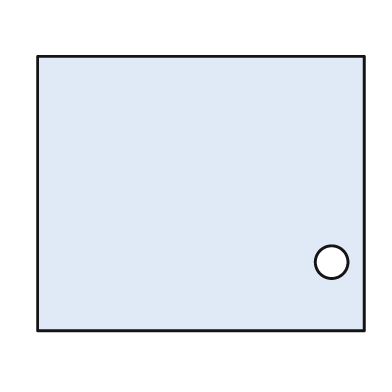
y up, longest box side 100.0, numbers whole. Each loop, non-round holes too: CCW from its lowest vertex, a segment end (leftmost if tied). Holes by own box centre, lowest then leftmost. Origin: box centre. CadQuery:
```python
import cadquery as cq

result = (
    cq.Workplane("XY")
    .moveTo(-50.0, -42.0)
    .lineTo(50.0, -42.0)
    .lineTo(50.0, 42.0)
    .lineTo(-50.0, 42.0)
    .close()
    .moveTo(40.0, -21.0)
    .circle(5.0)
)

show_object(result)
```